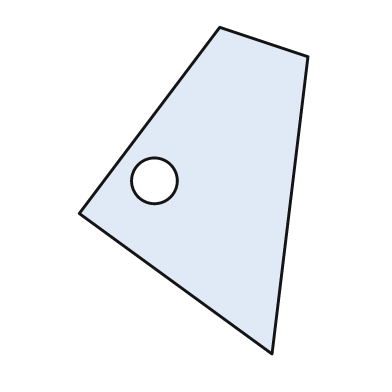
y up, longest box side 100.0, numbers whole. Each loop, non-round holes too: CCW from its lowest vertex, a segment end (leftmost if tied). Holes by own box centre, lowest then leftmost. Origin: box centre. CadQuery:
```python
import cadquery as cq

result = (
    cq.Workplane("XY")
    .moveTo(24.0, -50.0)
    .lineTo(35.0, 41.0)
    .lineTo(8.0, 50.0)
    .lineTo(-35.0, -7.0)
    .close()
    .moveTo(-12.0, 3.0)
    .circle(7.0)
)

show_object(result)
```